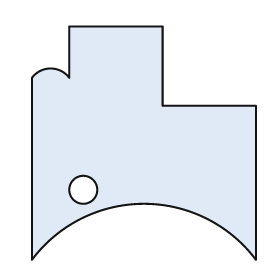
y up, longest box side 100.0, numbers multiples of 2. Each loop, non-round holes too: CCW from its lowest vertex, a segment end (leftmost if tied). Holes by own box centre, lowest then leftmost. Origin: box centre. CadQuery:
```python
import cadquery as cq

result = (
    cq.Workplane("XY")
    .moveTo(-48.0, -50.0)
    .threePointArc((0.0, -26.0), (48.0, -50.0))
    .lineTo(48.0, 16.0)
    .lineTo(8.0, 16.0)
    .lineTo(8.0, 50.0)
    .lineTo(-32.0, 50.0)
    .lineTo(-32.0, 28.0)
    .threePointArc((-40.0, 32.0), (-48.0, 28.0))
    .close()
    .moveTo(-26.0, -20.0)
    .circle(6.0)
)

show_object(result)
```